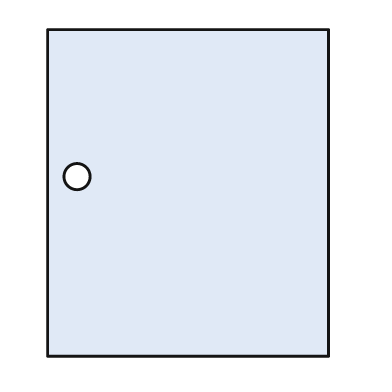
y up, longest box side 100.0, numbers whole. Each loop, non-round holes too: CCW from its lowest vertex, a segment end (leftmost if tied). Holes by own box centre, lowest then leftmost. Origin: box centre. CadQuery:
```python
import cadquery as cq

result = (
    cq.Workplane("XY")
    .moveTo(-43.0, -50.0)
    .lineTo(43.0, -50.0)
    .lineTo(43.0, 50.0)
    .lineTo(-43.0, 50.0)
    .close()
    .moveTo(-34.0, 5.0)
    .circle(4.0)
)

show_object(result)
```